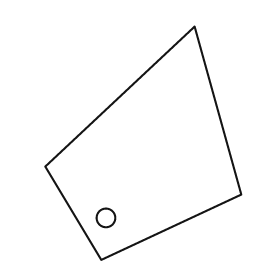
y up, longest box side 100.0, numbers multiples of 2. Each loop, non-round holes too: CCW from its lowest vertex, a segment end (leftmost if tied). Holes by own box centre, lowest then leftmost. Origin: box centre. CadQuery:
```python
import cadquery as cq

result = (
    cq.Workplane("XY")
    .moveTo(-18.0, -50.0)
    .lineTo(42.0, -22.0)
    .lineTo(22.0, 50.0)
    .lineTo(-42.0, -10.0)
    .close()
    .moveTo(-16.0, -32.0)
    .circle(4.0)
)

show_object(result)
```